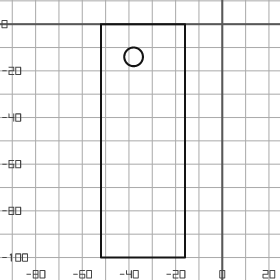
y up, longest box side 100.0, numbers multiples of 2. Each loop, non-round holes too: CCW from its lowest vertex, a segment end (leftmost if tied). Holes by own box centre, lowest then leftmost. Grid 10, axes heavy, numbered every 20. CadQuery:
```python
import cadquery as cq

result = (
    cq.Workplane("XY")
    .moveTo(-52.0, -100.0)
    .lineTo(-16.0, -100.0)
    .lineTo(-16.0, 0.0)
    .lineTo(-52.0, 0.0)
    .close()
    .moveTo(-38.0, -14.0)
    .circle(4.0)
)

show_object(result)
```